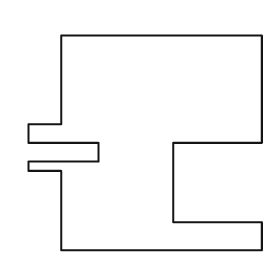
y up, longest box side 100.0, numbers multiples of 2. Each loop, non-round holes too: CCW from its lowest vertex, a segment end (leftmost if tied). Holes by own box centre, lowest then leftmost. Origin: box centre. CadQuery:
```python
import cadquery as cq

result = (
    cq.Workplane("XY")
    .moveTo(-36.0, -46.0)
    .lineTo(50.0, -46.0)
    .lineTo(50.0, -34.0)
    .lineTo(12.0, -34.0)
    .lineTo(12.0, 0.0)
    .lineTo(50.0, 0.0)
    .lineTo(50.0, 46.0)
    .lineTo(-36.0, 46.0)
    .lineTo(-36.0, 8.0)
    .lineTo(-50.0, 8.0)
    .lineTo(-50.0, 0.0)
    .lineTo(-20.0, 0.0)
    .lineTo(-20.0, -8.0)
    .lineTo(-50.0, -8.0)
    .lineTo(-50.0, -12.0)
    .lineTo(-36.0, -12.0)
    .close()
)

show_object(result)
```